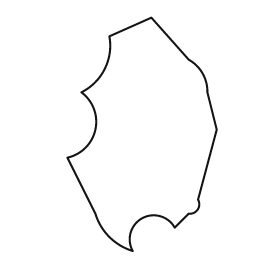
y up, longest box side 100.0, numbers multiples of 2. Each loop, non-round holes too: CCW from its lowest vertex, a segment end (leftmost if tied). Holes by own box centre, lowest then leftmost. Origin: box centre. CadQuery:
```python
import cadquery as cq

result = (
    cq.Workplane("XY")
    .moveTo(-4.0, -50.0)
    .threePointArc((0.0, -36.0), (14.0, -40.0))
    .lineTo(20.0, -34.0)
    .threePointArc((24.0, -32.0), (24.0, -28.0))
    .lineTo(32.0, 2.0)
    .lineTo(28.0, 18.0)
    .threePointArc((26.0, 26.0), (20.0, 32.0))
    .lineTo(4.0, 50.0)
    .lineTo(-14.0, 42.0)
    .threePointArc((-16.0, 28.0), (-26.0, 18.0))
    .threePointArc((-20.0, 2.0), (-32.0, -10.0))
    .lineTo(-20.0, -34.0)
    .threePointArc((-14.0, -44.0), (-4.0, -50.0))
    .close()
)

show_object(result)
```